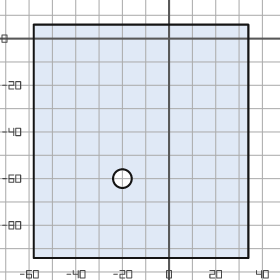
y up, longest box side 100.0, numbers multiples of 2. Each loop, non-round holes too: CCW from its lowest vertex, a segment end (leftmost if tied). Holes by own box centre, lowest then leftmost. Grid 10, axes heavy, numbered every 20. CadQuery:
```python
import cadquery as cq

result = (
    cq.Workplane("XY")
    .moveTo(-58.0, -94.0)
    .lineTo(34.0, -94.0)
    .lineTo(34.0, 6.0)
    .lineTo(-58.0, 6.0)
    .close()
    .moveTo(-20.0, -60.0)
    .circle(4.0)
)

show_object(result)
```